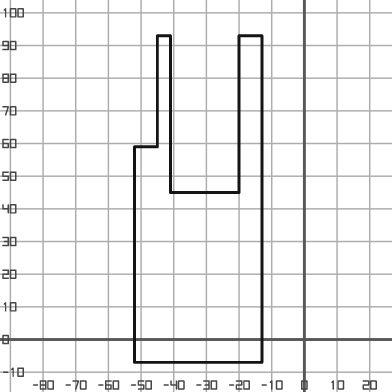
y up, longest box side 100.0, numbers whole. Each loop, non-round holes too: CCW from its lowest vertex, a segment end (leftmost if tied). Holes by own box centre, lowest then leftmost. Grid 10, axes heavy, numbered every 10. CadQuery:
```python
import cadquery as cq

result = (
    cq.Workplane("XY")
    .moveTo(-52.0, -7.0)
    .lineTo(-13.0, -7.0)
    .lineTo(-13.0, 93.0)
    .lineTo(-20.0, 93.0)
    .lineTo(-20.0, 45.0)
    .lineTo(-41.0, 45.0)
    .lineTo(-41.0, 93.0)
    .lineTo(-45.0, 93.0)
    .lineTo(-45.0, 59.0)
    .lineTo(-52.0, 59.0)
    .close()
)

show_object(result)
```